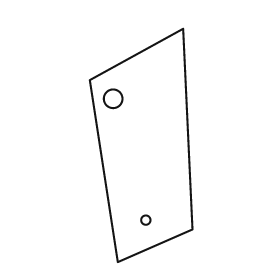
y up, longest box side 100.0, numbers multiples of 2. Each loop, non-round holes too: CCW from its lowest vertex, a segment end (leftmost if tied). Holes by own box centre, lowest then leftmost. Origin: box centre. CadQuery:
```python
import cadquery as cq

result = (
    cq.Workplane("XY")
    .moveTo(-10.0, -50.0)
    .lineTo(22.0, -36.0)
    .lineTo(18.0, 50.0)
    .lineTo(-22.0, 28.0)
    .close()
    .moveTo(2.0, -32.0)
    .circle(2.0)
    .moveTo(-12.0, 20.0)
    .circle(4.0)
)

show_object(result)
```